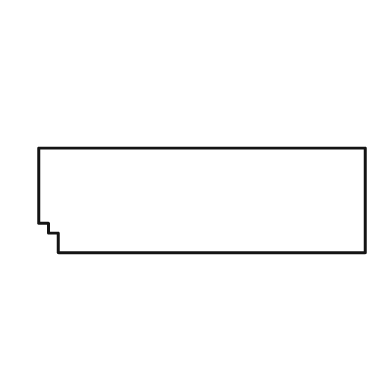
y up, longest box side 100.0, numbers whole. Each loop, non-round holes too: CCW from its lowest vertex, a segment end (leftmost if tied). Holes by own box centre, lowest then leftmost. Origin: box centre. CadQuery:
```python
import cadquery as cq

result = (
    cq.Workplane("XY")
    .moveTo(-44.0, -16.0)
    .lineTo(50.0, -16.0)
    .lineTo(50.0, 16.0)
    .lineTo(-50.0, 16.0)
    .lineTo(-50.0, -7.0)
    .lineTo(-47.0, -7.0)
    .lineTo(-47.0, -10.0)
    .lineTo(-44.0, -10.0)
    .close()
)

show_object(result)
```